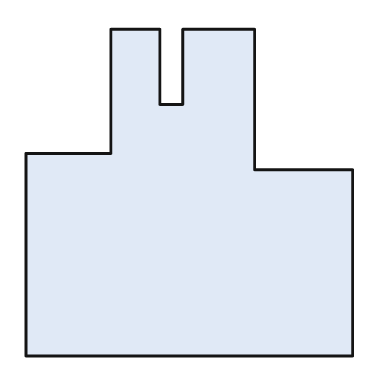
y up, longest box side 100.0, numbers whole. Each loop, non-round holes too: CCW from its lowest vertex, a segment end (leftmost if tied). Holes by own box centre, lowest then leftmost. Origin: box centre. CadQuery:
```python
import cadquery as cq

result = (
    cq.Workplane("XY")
    .moveTo(-50.0, -50.0)
    .lineTo(50.0, -50.0)
    .lineTo(50.0, 7.0)
    .lineTo(20.0, 7.0)
    .lineTo(20.0, 50.0)
    .lineTo(-2.0, 50.0)
    .lineTo(-2.0, 27.0)
    .lineTo(-9.0, 27.0)
    .lineTo(-9.0, 50.0)
    .lineTo(-24.0, 50.0)
    .lineTo(-24.0, 12.0)
    .lineTo(-50.0, 12.0)
    .close()
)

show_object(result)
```